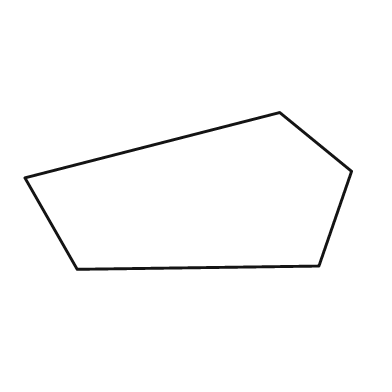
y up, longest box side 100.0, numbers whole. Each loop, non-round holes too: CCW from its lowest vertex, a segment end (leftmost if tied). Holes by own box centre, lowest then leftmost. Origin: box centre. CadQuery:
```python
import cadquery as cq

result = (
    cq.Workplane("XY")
    .moveTo(-34.0, -24.0)
    .lineTo(40.0, -23.0)
    .lineTo(50.0, 6.0)
    .lineTo(28.0, 24.0)
    .lineTo(-50.0, 4.0)
    .close()
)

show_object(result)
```